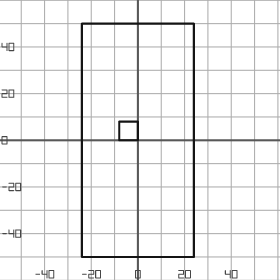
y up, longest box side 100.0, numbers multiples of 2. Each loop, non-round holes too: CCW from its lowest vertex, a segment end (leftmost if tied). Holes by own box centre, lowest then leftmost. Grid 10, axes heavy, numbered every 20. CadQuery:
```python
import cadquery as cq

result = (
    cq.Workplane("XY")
    .moveTo(-24.0, -50.0)
    .lineTo(24.0, -50.0)
    .lineTo(24.0, 50.0)
    .lineTo(-24.0, 50.0)
    .close()
    .moveTo(-8.0, 0.0)
    .lineTo(0.0, 0.0)
    .lineTo(0.0, 8.0)
    .lineTo(-8.0, 8.0)
    .close()
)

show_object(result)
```